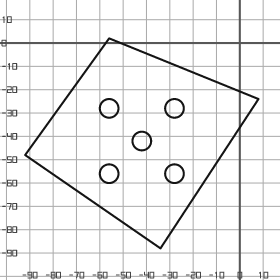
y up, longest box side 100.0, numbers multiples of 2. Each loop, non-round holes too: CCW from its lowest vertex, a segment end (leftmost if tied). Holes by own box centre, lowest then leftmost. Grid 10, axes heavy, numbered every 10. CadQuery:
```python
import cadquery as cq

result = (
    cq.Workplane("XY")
    .moveTo(-34.0, -88.0)
    .lineTo(8.0, -24.0)
    .lineTo(-56.0, 2.0)
    .lineTo(-92.0, -48.0)
    .close()
    .moveTo(-56.0, -56.0)
    .circle(4.0)
    .moveTo(-28.0, -56.0)
    .circle(4.0)
    .moveTo(-42.0, -42.0)
    .circle(4.0)
    .moveTo(-56.0, -28.0)
    .circle(4.0)
    .moveTo(-28.0, -28.0)
    .circle(4.0)
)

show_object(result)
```